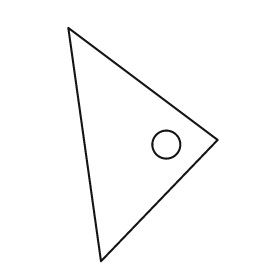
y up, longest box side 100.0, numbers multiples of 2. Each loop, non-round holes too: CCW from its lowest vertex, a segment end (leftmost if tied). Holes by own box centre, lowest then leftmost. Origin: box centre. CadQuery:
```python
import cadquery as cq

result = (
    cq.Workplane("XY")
    .moveTo(-18.0, -50.0)
    .lineTo(32.0, 2.0)
    .lineTo(-32.0, 50.0)
    .close()
    .moveTo(10.0, 0.0)
    .circle(6.0)
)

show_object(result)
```